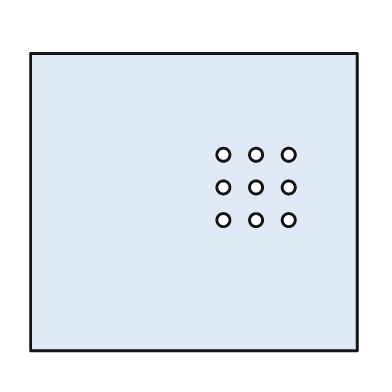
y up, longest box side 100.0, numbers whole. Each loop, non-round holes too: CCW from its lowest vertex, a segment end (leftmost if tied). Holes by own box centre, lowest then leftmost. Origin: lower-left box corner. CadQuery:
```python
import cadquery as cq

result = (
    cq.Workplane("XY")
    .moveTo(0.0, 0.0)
    .lineTo(100.0, 0.0)
    .lineTo(100.0, 91.0)
    .lineTo(0.0, 91.0)
    .close()
    .moveTo(59.0, 40.0)
    .circle(2.0)
    .moveTo(69.0, 40.0)
    .circle(2.0)
    .moveTo(79.0, 40.0)
    .circle(2.0)
    .moveTo(59.0, 50.0)
    .circle(2.0)
    .moveTo(69.0, 50.0)
    .circle(2.0)
    .moveTo(79.0, 50.0)
    .circle(2.0)
    .moveTo(59.0, 60.0)
    .circle(2.0)
    .moveTo(69.0, 60.0)
    .circle(2.0)
    .moveTo(79.0, 60.0)
    .circle(2.0)
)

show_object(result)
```